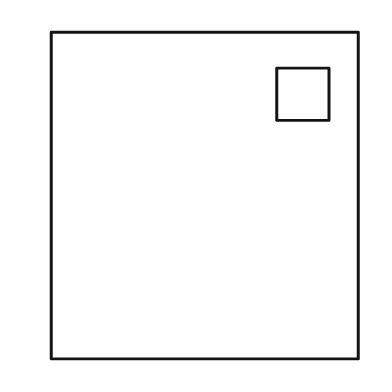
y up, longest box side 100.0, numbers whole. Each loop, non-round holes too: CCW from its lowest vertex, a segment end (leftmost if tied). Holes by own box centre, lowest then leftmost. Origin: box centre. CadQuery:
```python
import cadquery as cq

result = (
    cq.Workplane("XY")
    .moveTo(-47.0, -50.0)
    .lineTo(47.0, -50.0)
    .lineTo(47.0, 50.0)
    .lineTo(-47.0, 50.0)
    .close()
    .moveTo(22.0, 23.0)
    .lineTo(38.0, 23.0)
    .lineTo(38.0, 39.0)
    .lineTo(22.0, 39.0)
    .close()
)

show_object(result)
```